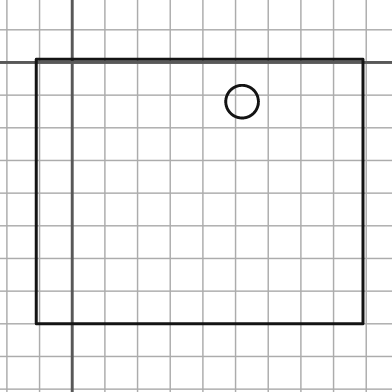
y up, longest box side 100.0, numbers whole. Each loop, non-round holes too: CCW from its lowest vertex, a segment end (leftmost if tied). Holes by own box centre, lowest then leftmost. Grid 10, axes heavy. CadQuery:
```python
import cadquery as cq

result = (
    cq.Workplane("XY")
    .moveTo(-11.0, -80.0)
    .lineTo(89.0, -80.0)
    .lineTo(89.0, 1.0)
    .lineTo(-11.0, 1.0)
    .close()
    .moveTo(52.0, -12.0)
    .circle(5.0)
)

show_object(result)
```